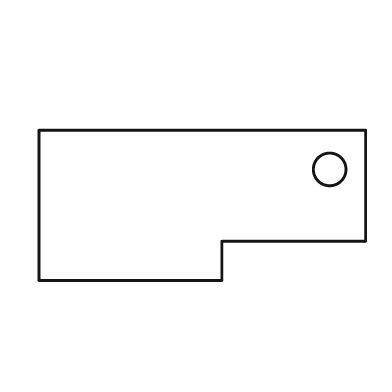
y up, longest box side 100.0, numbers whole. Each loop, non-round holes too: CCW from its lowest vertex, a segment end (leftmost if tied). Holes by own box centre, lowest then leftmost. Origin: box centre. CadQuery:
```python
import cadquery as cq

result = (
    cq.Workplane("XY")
    .moveTo(-50.0, -23.0)
    .lineTo(6.0, -23.0)
    .lineTo(6.0, -11.0)
    .lineTo(50.0, -11.0)
    .lineTo(50.0, 23.0)
    .lineTo(-50.0, 23.0)
    .close()
    .moveTo(39.0, 11.0)
    .circle(5.0)
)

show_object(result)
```